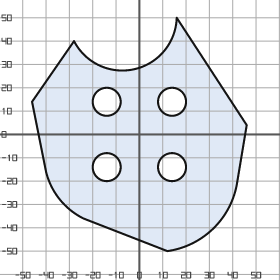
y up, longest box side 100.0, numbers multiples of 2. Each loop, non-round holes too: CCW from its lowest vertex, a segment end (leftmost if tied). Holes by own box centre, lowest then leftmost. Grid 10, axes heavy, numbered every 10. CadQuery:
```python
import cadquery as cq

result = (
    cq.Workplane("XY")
    .moveTo(12.0, -50.0)
    .threePointArc((32.0, -40.0), (42.0, -20.0))
    .lineTo(46.0, 4.0)
    .lineTo(16.0, 50.0)
    .threePointArc((-2.0, 28.0), (-28.0, 40.0))
    .lineTo(-46.0, 14.0)
    .lineTo(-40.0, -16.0)
    .threePointArc((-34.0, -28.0), (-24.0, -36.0))
    .close()
    .moveTo(-14.0, -14.0)
    .circle(6.0)
    .moveTo(14.0, -14.0)
    .circle(6.0)
    .moveTo(-14.0, 14.0)
    .circle(6.0)
    .moveTo(14.0, 14.0)
    .circle(6.0)
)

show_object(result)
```